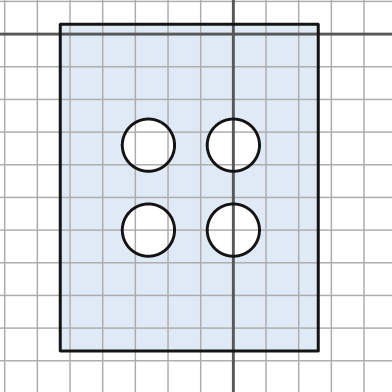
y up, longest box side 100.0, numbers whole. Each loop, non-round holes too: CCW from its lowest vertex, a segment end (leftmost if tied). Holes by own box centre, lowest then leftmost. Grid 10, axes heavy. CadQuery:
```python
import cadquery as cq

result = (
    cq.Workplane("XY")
    .moveTo(-53.0, -97.0)
    .lineTo(26.0, -97.0)
    .lineTo(26.0, 3.0)
    .lineTo(-53.0, 3.0)
    .close()
    .moveTo(-26.0, -60.0)
    .circle(8.0)
    .moveTo(0.0, -60.0)
    .circle(8.0)
    .moveTo(-26.0, -34.0)
    .circle(8.0)
    .moveTo(0.0, -34.0)
    .circle(8.0)
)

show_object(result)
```